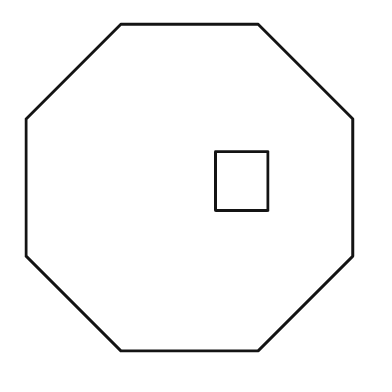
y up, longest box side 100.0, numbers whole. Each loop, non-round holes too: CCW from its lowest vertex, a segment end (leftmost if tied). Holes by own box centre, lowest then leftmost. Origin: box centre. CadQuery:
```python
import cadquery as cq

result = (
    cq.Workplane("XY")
    .moveTo(-21.0, -50.0)
    .lineTo(21.0, -50.0)
    .lineTo(50.0, -21.0)
    .lineTo(50.0, 21.0)
    .lineTo(21.0, 50.0)
    .lineTo(-21.0, 50.0)
    .lineTo(-50.0, 21.0)
    .lineTo(-50.0, -21.0)
    .close()
    .moveTo(8.0, -7.0)
    .lineTo(24.0, -7.0)
    .lineTo(24.0, 11.0)
    .lineTo(8.0, 11.0)
    .close()
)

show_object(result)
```